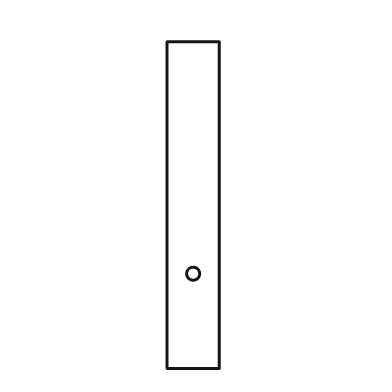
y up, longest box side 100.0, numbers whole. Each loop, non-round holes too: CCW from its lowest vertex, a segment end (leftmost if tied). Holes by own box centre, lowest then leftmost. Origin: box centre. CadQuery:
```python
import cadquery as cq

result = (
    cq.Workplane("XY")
    .moveTo(-8.0, -50.0)
    .lineTo(8.0, -50.0)
    .lineTo(8.0, 50.0)
    .lineTo(-8.0, 50.0)
    .close()
    .moveTo(0.0, -21.0)
    .circle(2.0)
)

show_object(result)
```